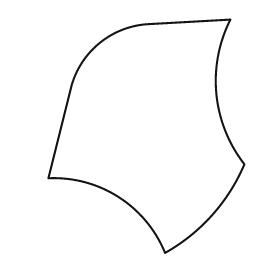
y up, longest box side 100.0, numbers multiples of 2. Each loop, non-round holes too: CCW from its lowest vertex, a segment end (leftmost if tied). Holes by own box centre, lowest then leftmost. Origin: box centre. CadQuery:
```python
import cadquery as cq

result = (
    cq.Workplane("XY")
    .moveTo(8.0, -50.0)
    .threePointArc((28.0, -34.0), (42.0, -12.0))
    .threePointArc((30.0, 18.0), (36.0, 50.0))
    .lineTo(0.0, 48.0)
    .threePointArc((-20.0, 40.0), (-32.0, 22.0))
    .lineTo(-42.0, -18.0)
    .threePointArc((-12.0, -26.0), (8.0, -50.0))
    .close()
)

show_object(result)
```